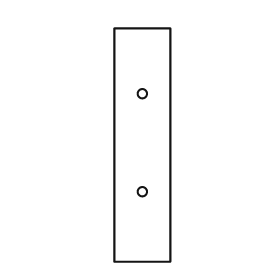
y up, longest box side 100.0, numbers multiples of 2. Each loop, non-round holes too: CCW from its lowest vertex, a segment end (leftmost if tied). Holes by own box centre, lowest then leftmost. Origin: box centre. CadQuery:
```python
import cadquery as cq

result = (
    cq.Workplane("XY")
    .moveTo(-12.0, -50.0)
    .lineTo(12.0, -50.0)
    .lineTo(12.0, 50.0)
    .lineTo(-12.0, 50.0)
    .close()
    .moveTo(0.0, -20.0)
    .circle(2.0)
    .moveTo(0.0, 22.0)
    .circle(2.0)
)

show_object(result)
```